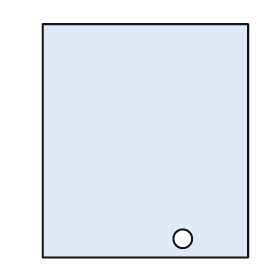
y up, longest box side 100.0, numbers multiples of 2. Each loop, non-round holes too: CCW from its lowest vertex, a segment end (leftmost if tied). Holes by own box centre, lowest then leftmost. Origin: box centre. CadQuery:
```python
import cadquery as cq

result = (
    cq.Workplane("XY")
    .moveTo(-44.0, -50.0)
    .lineTo(44.0, -50.0)
    .lineTo(44.0, 50.0)
    .lineTo(-44.0, 50.0)
    .close()
    .moveTo(16.0, -42.0)
    .circle(4.0)
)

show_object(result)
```